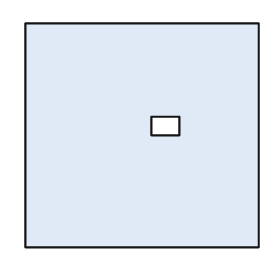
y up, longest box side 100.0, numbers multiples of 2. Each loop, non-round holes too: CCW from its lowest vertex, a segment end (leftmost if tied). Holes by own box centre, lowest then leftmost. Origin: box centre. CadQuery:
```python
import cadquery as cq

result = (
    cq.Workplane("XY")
    .moveTo(-50.0, -48.0)
    .lineTo(50.0, -48.0)
    .lineTo(50.0, 48.0)
    .lineTo(-50.0, 48.0)
    .close()
    .moveTo(4.0, 0.0)
    .lineTo(16.0, 0.0)
    .lineTo(16.0, 8.0)
    .lineTo(4.0, 8.0)
    .close()
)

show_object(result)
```